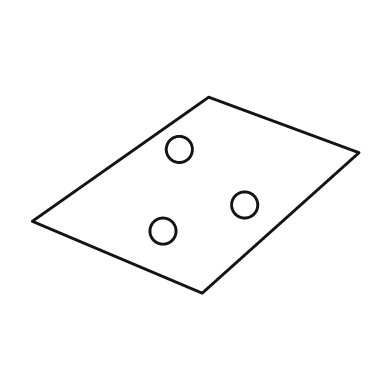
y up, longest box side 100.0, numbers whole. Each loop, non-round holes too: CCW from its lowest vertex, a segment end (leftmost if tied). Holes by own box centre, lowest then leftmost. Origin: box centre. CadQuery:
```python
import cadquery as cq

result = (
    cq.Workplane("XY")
    .moveTo(2.0, -30.0)
    .lineTo(50.0, 13.0)
    .lineTo(4.0, 30.0)
    .lineTo(-50.0, -8.0)
    .close()
    .moveTo(-10.0, -11.0)
    .circle(4.0)
    .moveTo(15.0, -3.0)
    .circle(4.0)
    .moveTo(-5.0, 14.0)
    .circle(4.0)
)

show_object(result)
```